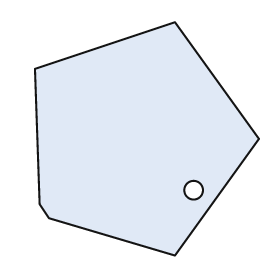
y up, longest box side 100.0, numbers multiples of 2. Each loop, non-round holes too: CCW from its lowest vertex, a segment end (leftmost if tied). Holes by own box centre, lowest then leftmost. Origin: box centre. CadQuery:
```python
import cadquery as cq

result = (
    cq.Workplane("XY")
    .moveTo(12.0, -50.0)
    .lineTo(48.0, 0.0)
    .lineTo(12.0, 50.0)
    .lineTo(-48.0, 30.0)
    .lineTo(-46.0, -28.0)
    .lineTo(-42.0, -34.0)
    .close()
    .moveTo(20.0, -22.0)
    .circle(4.0)
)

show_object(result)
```